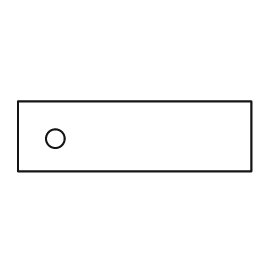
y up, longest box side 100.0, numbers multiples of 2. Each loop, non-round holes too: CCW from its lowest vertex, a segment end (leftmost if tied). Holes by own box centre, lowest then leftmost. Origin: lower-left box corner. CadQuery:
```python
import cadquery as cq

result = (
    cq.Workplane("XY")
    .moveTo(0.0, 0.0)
    .lineTo(100.0, 0.0)
    .lineTo(100.0, 30.0)
    .lineTo(0.0, 30.0)
    .close()
    .moveTo(16.0, 14.0)
    .circle(4.0)
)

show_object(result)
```